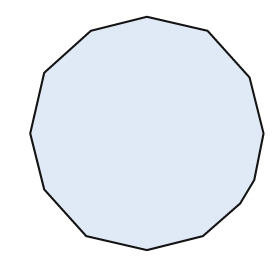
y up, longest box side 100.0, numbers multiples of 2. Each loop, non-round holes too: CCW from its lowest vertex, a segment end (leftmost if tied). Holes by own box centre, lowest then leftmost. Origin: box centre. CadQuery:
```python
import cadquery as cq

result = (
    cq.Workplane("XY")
    .moveTo(0.0, -50.0)
    .lineTo(24.0, -44.0)
    .lineTo(40.0, -30.0)
    .lineTo(46.0, -20.0)
    .lineTo(50.0, 0.0)
    .lineTo(44.0, 24.0)
    .lineTo(26.0, 44.0)
    .lineTo(0.0, 50.0)
    .lineTo(-24.0, 44.0)
    .lineTo(-44.0, 26.0)
    .lineTo(-50.0, 0.0)
    .lineTo(-44.0, -24.0)
    .lineTo(-26.0, -44.0)
    .close()
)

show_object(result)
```